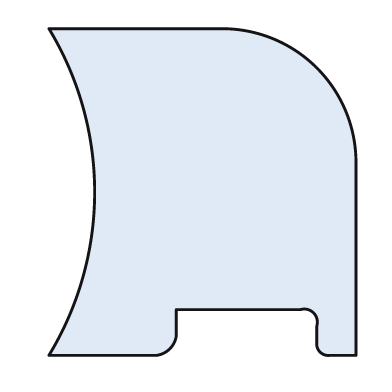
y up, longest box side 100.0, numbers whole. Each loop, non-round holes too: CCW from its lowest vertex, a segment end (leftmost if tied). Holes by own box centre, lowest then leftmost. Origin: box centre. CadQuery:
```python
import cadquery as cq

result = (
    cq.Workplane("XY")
    .moveTo(-47.0, -50.0)
    .lineTo(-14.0, -50.0)
    .threePointArc((-10.0, -48.0), (-8.0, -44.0))
    .lineTo(-8.0, -36.0)
    .lineTo(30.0, -36.0)
    .threePointArc((34.0, -37.0), (35.0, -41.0))
    .lineTo(35.0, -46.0)
    .threePointArc((36.0, -49.0), (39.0, -50.0))
    .lineTo(47.0, -50.0)
    .lineTo(47.0, 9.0)
    .threePointArc((35.0, 38.0), (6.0, 50.0))
    .lineTo(-47.0, 50.0)
    .threePointArc((-33.0, 0.0), (-47.0, -50.0))
    .close()
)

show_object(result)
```